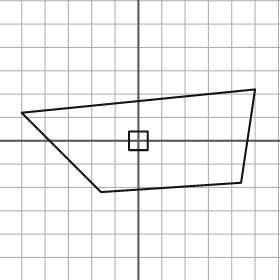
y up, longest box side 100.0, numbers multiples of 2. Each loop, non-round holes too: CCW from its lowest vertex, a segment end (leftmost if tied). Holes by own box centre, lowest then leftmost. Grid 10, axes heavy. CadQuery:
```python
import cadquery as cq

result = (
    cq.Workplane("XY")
    .moveTo(-16.0, -22.0)
    .lineTo(44.0, -18.0)
    .lineTo(50.0, 22.0)
    .lineTo(-50.0, 12.0)
    .close()
    .moveTo(-4.0, -4.0)
    .lineTo(4.0, -4.0)
    .lineTo(4.0, 4.0)
    .lineTo(-4.0, 4.0)
    .close()
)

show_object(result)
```